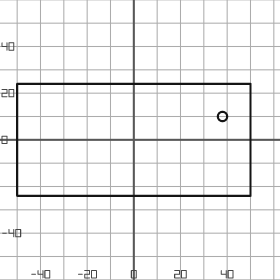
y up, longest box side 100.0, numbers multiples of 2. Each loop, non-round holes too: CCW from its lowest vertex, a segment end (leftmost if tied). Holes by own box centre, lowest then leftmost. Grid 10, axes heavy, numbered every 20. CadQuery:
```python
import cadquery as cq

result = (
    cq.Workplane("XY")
    .moveTo(-50.0, -24.0)
    .lineTo(50.0, -24.0)
    .lineTo(50.0, 24.0)
    .lineTo(-50.0, 24.0)
    .close()
    .moveTo(38.0, 10.0)
    .circle(2.0)
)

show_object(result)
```